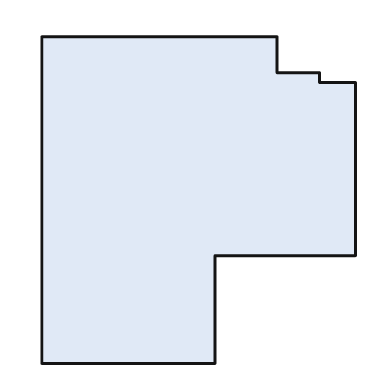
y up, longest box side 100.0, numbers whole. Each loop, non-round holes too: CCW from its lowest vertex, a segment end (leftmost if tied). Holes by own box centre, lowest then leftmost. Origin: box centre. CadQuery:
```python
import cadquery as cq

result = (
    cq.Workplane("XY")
    .moveTo(-48.0, -50.0)
    .lineTo(5.0, -50.0)
    .lineTo(5.0, -17.0)
    .lineTo(48.0, -17.0)
    .lineTo(48.0, 36.0)
    .lineTo(37.0, 36.0)
    .lineTo(37.0, 39.0)
    .lineTo(24.0, 39.0)
    .lineTo(24.0, 50.0)
    .lineTo(-48.0, 50.0)
    .close()
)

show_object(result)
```